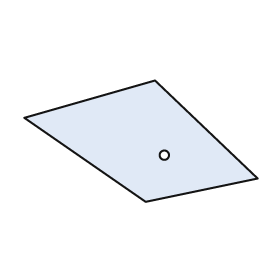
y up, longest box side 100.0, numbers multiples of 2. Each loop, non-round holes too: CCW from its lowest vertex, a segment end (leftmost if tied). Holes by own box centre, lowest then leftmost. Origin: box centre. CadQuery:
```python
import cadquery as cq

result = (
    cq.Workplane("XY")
    .moveTo(2.0, -26.0)
    .lineTo(50.0, -16.0)
    .lineTo(6.0, 26.0)
    .lineTo(-50.0, 10.0)
    .close()
    .moveTo(10.0, -6.0)
    .circle(2.0)
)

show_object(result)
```